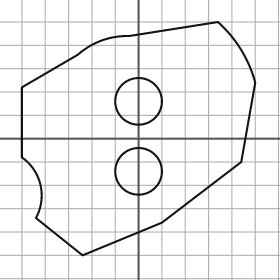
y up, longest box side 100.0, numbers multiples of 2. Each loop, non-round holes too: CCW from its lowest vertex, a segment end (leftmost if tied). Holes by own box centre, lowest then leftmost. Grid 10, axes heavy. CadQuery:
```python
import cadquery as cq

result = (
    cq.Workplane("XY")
    .moveTo(-24.0, -50.0)
    .lineTo(10.0, -36.0)
    .lineTo(44.0, -10.0)
    .lineTo(50.0, 24.0)
    .threePointArc((44.0, 38.0), (34.0, 50.0))
    .lineTo(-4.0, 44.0)
    .threePointArc((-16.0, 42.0), (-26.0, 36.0))
    .lineTo(-50.0, 22.0)
    .lineTo(-50.0, -8.0)
    .threePointArc((-42.0, -20.0), (-44.0, -34.0))
    .close()
    .moveTo(0.0, -14.0)
    .circle(10.0)
    .moveTo(0.0, 16.0)
    .circle(10.0)
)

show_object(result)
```